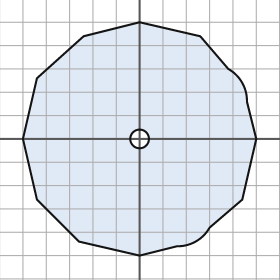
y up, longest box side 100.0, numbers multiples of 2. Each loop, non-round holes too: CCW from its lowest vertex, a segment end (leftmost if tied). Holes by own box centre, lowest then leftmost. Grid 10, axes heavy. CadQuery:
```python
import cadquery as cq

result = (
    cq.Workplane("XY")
    .moveTo(0.0, -50.0)
    .lineTo(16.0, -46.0)
    .threePointArc((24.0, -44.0), (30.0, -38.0))
    .lineTo(44.0, -26.0)
    .lineTo(50.0, 0.0)
    .lineTo(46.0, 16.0)
    .threePointArc((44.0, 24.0), (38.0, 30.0))
    .lineTo(26.0, 44.0)
    .lineTo(0.0, 50.0)
    .lineTo(-24.0, 44.0)
    .lineTo(-44.0, 26.0)
    .lineTo(-50.0, 0.0)
    .lineTo(-44.0, -26.0)
    .lineTo(-26.0, -44.0)
    .close()
    .moveTo(0.0, 0.0)
    .circle(4.0)
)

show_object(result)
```